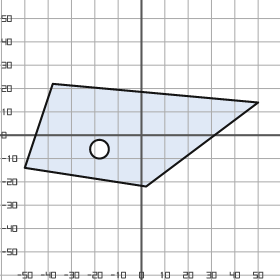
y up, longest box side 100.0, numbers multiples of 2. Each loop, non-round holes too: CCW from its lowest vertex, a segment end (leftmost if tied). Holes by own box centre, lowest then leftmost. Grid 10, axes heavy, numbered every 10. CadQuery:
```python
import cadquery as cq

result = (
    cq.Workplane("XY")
    .moveTo(2.0, -22.0)
    .lineTo(50.0, 14.0)
    .lineTo(-38.0, 22.0)
    .lineTo(-50.0, -14.0)
    .close()
    .moveTo(-18.0, -6.0)
    .circle(4.0)
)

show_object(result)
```